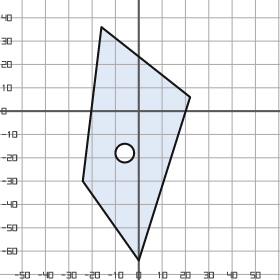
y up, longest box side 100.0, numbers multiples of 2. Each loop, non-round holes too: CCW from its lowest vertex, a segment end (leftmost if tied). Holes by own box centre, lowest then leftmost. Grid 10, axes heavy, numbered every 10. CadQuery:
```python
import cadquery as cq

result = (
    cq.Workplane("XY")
    .moveTo(0.0, -64.0)
    .lineTo(22.0, 6.0)
    .lineTo(-16.0, 36.0)
    .lineTo(-24.0, -30.0)
    .close()
    .moveTo(-6.0, -18.0)
    .circle(4.0)
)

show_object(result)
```